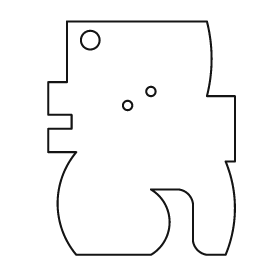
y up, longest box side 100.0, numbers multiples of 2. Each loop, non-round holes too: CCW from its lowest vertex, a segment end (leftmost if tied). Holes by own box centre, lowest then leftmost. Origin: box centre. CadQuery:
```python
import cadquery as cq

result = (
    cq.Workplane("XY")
    .moveTo(-28.0, -50.0)
    .lineTo(4.0, -50.0)
    .threePointArc((12.0, -36.0), (4.0, -22.0))
    .lineTo(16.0, -22.0)
    .threePointArc((20.0, -24.0), (22.0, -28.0))
    .lineTo(22.0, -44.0)
    .threePointArc((24.0, -48.0), (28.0, -50.0))
    .lineTo(36.0, -50.0)
    .threePointArc((40.0, -30.0), (36.0, -10.0))
    .lineTo(40.0, -10.0)
    .lineTo(40.0, 18.0)
    .lineTo(28.0, 18.0)
    .threePointArc((30.0, 34.0), (28.0, 50.0))
    .lineTo(-32.0, 50.0)
    .lineTo(-32.0, 24.0)
    .lineTo(-40.0, 24.0)
    .lineTo(-40.0, 10.0)
    .lineTo(-30.0, 10.0)
    .lineTo(-30.0, 4.0)
    .lineTo(-40.0, 4.0)
    .lineTo(-40.0, -6.0)
    .lineTo(-28.0, -6.0)
    .threePointArc((-36.0, -28.0), (-28.0, -50.0))
    .close()
    .moveTo(-6.0, 14.0)
    .circle(2.0)
    .moveTo(4.0, 20.0)
    .circle(2.0)
    .moveTo(-22.0, 42.0)
    .circle(4.0)
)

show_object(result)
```